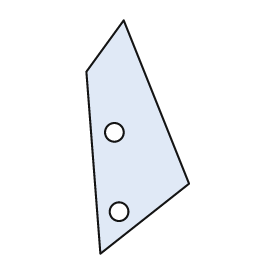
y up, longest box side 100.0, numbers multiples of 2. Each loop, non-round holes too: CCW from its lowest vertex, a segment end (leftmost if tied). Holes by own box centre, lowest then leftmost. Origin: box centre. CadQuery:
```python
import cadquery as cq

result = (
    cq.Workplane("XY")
    .moveTo(-16.0, -50.0)
    .lineTo(22.0, -20.0)
    .lineTo(-6.0, 50.0)
    .lineTo(-22.0, 28.0)
    .close()
    .moveTo(-8.0, -32.0)
    .circle(4.0)
    .moveTo(-10.0, 2.0)
    .circle(4.0)
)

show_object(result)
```